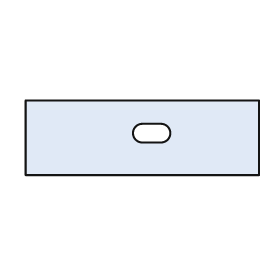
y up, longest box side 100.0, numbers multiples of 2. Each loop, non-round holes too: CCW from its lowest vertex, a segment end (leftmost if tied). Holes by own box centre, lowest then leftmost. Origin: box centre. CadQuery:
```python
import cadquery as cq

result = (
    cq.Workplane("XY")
    .moveTo(-50.0, -16.0)
    .lineTo(50.0, -16.0)
    .lineTo(50.0, 16.0)
    .lineTo(-50.0, 16.0)
    .close()
    .moveTo(0.0, -2.0)
    .lineTo(8.0, -2.0)
    .threePointArc((12.0, 2.0), (8.0, 6.0))
    .lineTo(0.0, 6.0)
    .threePointArc((-4.0, 2.0), (0.0, -2.0))
    .close()
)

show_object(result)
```